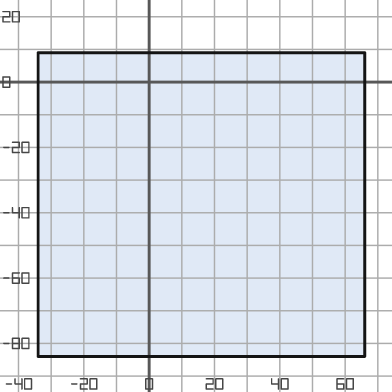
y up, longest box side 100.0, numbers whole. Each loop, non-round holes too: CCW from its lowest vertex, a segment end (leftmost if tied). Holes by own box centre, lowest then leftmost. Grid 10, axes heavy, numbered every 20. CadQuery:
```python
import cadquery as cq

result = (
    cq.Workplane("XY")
    .moveTo(-34.0, -84.0)
    .lineTo(66.0, -84.0)
    .lineTo(66.0, 9.0)
    .lineTo(-34.0, 9.0)
    .close()
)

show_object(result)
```